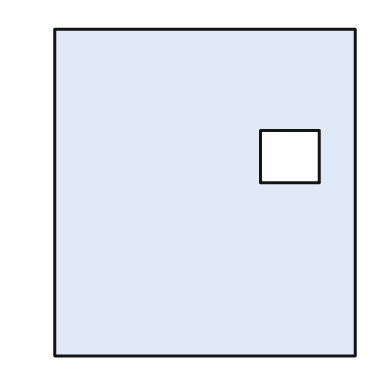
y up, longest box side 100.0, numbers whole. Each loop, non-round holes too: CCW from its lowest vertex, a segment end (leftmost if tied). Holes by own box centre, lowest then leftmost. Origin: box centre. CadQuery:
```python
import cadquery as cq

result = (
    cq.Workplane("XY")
    .moveTo(-46.0, -50.0)
    .lineTo(46.0, -50.0)
    .lineTo(46.0, 50.0)
    .lineTo(-46.0, 50.0)
    .close()
    .moveTo(17.0, 3.0)
    .lineTo(35.0, 3.0)
    .lineTo(35.0, 19.0)
    .lineTo(17.0, 19.0)
    .close()
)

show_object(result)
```